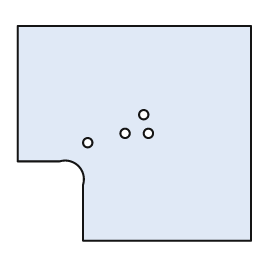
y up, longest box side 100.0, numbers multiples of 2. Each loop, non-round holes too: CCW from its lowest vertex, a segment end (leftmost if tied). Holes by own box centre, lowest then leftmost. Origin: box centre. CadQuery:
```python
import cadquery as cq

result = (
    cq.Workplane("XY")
    .moveTo(-22.0, -46.0)
    .lineTo(50.0, -46.0)
    .lineTo(50.0, 46.0)
    .lineTo(-50.0, 46.0)
    .lineTo(-50.0, -12.0)
    .lineTo(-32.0, -12.0)
    .threePointArc((-24.0, -14.0), (-22.0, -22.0))
    .close()
    .moveTo(-20.0, -4.0)
    .circle(2.0)
    .moveTo(-4.0, 0.0)
    .circle(2.0)
    .moveTo(6.0, 0.0)
    .circle(2.0)
    .moveTo(4.0, 8.0)
    .circle(2.0)
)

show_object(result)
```